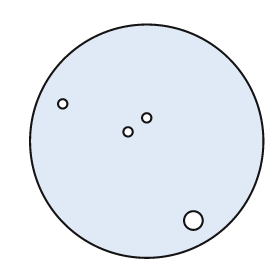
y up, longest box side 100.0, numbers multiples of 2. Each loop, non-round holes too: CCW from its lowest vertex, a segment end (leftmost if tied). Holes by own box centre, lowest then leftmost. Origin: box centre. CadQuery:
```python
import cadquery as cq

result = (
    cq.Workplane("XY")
    .moveTo(0.0, 0.0)
    .circle(50.0)
    .moveTo(20.0, -34.0)
    .circle(4.0)
    .moveTo(-8.0, 4.0)
    .circle(2.0)
    .moveTo(0.0, 10.0)
    .circle(2.0)
    .moveTo(-36.0, 16.0)
    .circle(2.0)
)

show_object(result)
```